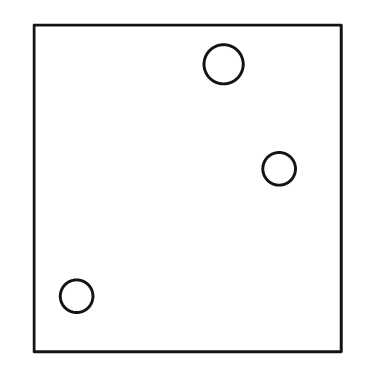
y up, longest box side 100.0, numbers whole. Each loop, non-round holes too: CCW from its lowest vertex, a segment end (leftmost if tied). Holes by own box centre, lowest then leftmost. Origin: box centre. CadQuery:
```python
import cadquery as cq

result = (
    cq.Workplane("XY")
    .moveTo(-47.0, -50.0)
    .lineTo(47.0, -50.0)
    .lineTo(47.0, 50.0)
    .lineTo(-47.0, 50.0)
    .close()
    .moveTo(-34.0, -33.0)
    .circle(5.0)
    .moveTo(28.0, 6.0)
    .circle(5.0)
    .moveTo(11.0, 38.0)
    .circle(6.0)
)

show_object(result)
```